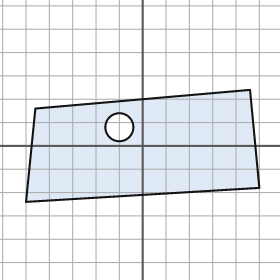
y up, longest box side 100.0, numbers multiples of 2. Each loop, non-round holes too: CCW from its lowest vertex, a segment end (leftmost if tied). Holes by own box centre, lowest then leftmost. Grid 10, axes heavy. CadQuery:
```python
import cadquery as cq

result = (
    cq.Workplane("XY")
    .moveTo(-50.0, -24.0)
    .lineTo(50.0, -18.0)
    .lineTo(46.0, 24.0)
    .lineTo(-46.0, 16.0)
    .close()
    .moveTo(-10.0, 8.0)
    .circle(6.0)
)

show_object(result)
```